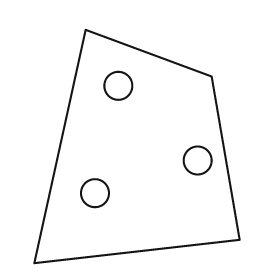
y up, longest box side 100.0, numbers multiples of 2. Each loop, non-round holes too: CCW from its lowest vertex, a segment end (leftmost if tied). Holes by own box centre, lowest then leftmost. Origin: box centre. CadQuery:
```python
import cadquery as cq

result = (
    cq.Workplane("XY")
    .moveTo(-44.0, -50.0)
    .lineTo(44.0, -40.0)
    .lineTo(32.0, 30.0)
    .lineTo(-22.0, 50.0)
    .close()
    .moveTo(-18.0, -20.0)
    .circle(6.0)
    .moveTo(26.0, -6.0)
    .circle(6.0)
    .moveTo(-8.0, 26.0)
    .circle(6.0)
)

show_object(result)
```